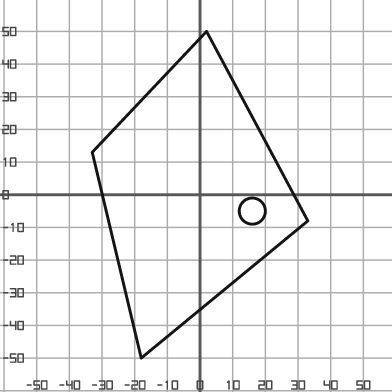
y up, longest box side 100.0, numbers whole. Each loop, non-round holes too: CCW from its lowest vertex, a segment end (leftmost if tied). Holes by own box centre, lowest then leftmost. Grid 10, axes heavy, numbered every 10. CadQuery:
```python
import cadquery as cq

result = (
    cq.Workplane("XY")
    .moveTo(-18.0, -50.0)
    .lineTo(33.0, -8.0)
    .lineTo(2.0, 50.0)
    .lineTo(-33.0, 13.0)
    .close()
    .moveTo(16.0, -5.0)
    .circle(4.0)
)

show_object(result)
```